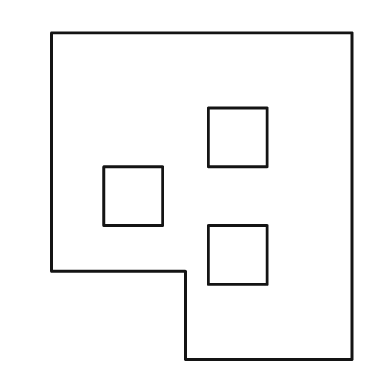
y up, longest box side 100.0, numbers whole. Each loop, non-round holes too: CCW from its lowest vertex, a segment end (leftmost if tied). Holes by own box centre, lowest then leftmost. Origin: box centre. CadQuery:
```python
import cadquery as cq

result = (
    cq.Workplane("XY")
    .moveTo(-5.0, -50.0)
    .lineTo(46.0, -50.0)
    .lineTo(46.0, 50.0)
    .lineTo(-46.0, 50.0)
    .lineTo(-46.0, -23.0)
    .lineTo(-5.0, -23.0)
    .close()
    .moveTo(2.0, -27.0)
    .lineTo(20.0, -27.0)
    .lineTo(20.0, -9.0)
    .lineTo(2.0, -9.0)
    .close()
    .moveTo(-30.0, -9.0)
    .lineTo(-12.0, -9.0)
    .lineTo(-12.0, 9.0)
    .lineTo(-30.0, 9.0)
    .close()
    .moveTo(2.0, 9.0)
    .lineTo(20.0, 9.0)
    .lineTo(20.0, 27.0)
    .lineTo(2.0, 27.0)
    .close()
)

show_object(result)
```